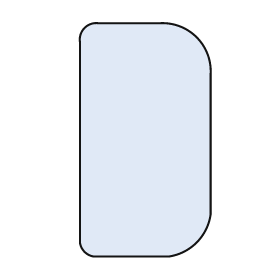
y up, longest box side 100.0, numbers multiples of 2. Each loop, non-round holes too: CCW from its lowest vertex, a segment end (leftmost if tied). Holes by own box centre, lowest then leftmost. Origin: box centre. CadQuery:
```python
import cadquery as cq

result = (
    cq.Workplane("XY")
    .moveTo(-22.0, -50.0)
    .lineTo(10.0, -50.0)
    .threePointArc((22.0, -44.0), (28.0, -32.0))
    .lineTo(28.0, 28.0)
    .threePointArc((22.0, 44.0), (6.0, 50.0))
    .lineTo(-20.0, 50.0)
    .threePointArc((-26.0, 48.0), (-28.0, 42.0))
    .lineTo(-28.0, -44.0)
    .threePointArc((-26.0, -48.0), (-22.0, -50.0))
    .close()
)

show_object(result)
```